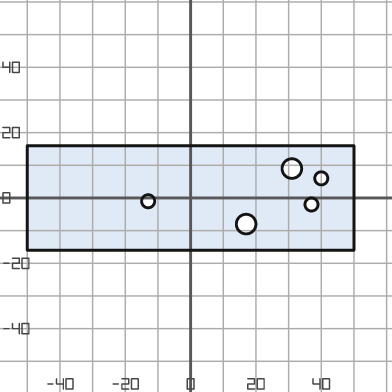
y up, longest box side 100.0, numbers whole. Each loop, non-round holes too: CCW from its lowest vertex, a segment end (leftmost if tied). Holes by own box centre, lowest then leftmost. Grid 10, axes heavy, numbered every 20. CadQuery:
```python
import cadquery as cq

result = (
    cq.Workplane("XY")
    .moveTo(-50.0, -16.0)
    .lineTo(50.0, -16.0)
    .lineTo(50.0, 16.0)
    .lineTo(-50.0, 16.0)
    .close()
    .moveTo(17.0, -8.0)
    .circle(3.0)
    .moveTo(37.0, -2.0)
    .circle(2.0)
    .moveTo(-13.0, -1.0)
    .circle(2.0)
    .moveTo(40.0, 6.0)
    .circle(2.0)
    .moveTo(31.0, 9.0)
    .circle(3.0)
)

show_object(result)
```